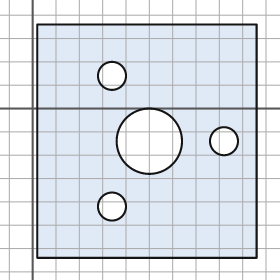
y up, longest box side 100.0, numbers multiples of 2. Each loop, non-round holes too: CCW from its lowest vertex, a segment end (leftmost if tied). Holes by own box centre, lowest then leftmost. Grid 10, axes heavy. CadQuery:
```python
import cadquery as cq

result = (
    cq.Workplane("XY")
    .moveTo(2.0, -64.0)
    .lineTo(96.0, -64.0)
    .lineTo(96.0, 36.0)
    .lineTo(2.0, 36.0)
    .close()
    .moveTo(34.0, -42.0)
    .circle(6.0)
    .moveTo(50.0, -14.0)
    .circle(14.0)
    .moveTo(82.0, -14.0)
    .circle(6.0)
    .moveTo(34.0, 14.0)
    .circle(6.0)
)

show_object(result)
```